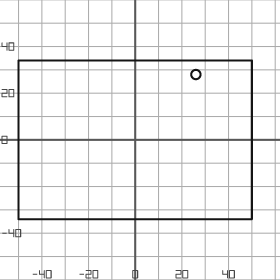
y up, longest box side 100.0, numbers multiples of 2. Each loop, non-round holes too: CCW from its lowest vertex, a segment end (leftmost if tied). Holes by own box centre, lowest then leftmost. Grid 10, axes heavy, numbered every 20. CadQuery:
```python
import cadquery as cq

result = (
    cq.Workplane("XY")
    .moveTo(-50.0, -34.0)
    .lineTo(50.0, -34.0)
    .lineTo(50.0, 34.0)
    .lineTo(-50.0, 34.0)
    .close()
    .moveTo(26.0, 28.0)
    .circle(2.0)
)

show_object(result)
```